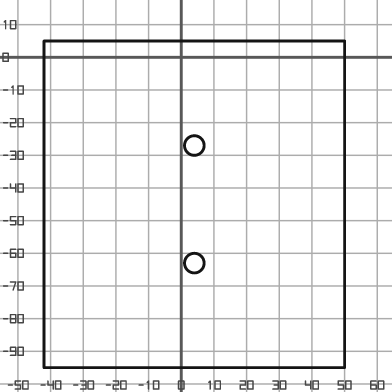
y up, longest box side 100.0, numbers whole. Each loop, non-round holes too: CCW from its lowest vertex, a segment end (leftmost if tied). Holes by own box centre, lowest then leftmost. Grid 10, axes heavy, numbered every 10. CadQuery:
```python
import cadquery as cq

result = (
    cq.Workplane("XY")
    .moveTo(-42.0, -95.0)
    .lineTo(50.0, -95.0)
    .lineTo(50.0, 5.0)
    .lineTo(-42.0, 5.0)
    .close()
    .moveTo(4.0, -63.0)
    .circle(3.0)
    .moveTo(4.0, -27.0)
    .circle(3.0)
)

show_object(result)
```